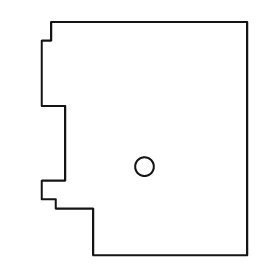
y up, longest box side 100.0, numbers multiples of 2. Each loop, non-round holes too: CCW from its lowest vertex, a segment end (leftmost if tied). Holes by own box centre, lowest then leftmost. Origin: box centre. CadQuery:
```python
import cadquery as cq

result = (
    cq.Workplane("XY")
    .moveTo(-22.0, -50.0)
    .lineTo(44.0, -50.0)
    .lineTo(44.0, 50.0)
    .lineTo(-40.0, 50.0)
    .lineTo(-40.0, 42.0)
    .lineTo(-44.0, 42.0)
    .lineTo(-44.0, 14.0)
    .lineTo(-34.0, 14.0)
    .lineTo(-34.0, -18.0)
    .lineTo(-44.0, -18.0)
    .lineTo(-44.0, -26.0)
    .lineTo(-38.0, -26.0)
    .lineTo(-38.0, -30.0)
    .lineTo(-22.0, -30.0)
    .close()
    .moveTo(0.0, -12.0)
    .circle(4.0)
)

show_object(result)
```